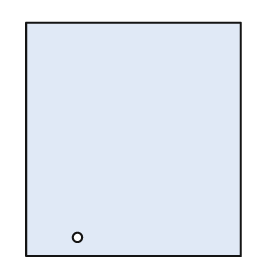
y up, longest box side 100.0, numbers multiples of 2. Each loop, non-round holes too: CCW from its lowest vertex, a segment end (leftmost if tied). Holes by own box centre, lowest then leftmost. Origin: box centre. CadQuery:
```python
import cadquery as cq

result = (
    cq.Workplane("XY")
    .moveTo(-46.0, -50.0)
    .lineTo(46.0, -50.0)
    .lineTo(46.0, 50.0)
    .lineTo(-46.0, 50.0)
    .close()
    .moveTo(-24.0, -42.0)
    .circle(2.0)
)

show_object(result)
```